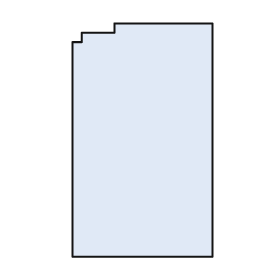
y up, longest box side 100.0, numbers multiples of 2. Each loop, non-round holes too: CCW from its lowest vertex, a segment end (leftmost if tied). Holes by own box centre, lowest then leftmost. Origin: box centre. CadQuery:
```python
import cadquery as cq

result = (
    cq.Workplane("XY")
    .moveTo(-30.0, -50.0)
    .lineTo(30.0, -50.0)
    .lineTo(30.0, 50.0)
    .lineTo(-12.0, 50.0)
    .lineTo(-12.0, 46.0)
    .lineTo(-26.0, 46.0)
    .lineTo(-26.0, 42.0)
    .lineTo(-30.0, 42.0)
    .close()
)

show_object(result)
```